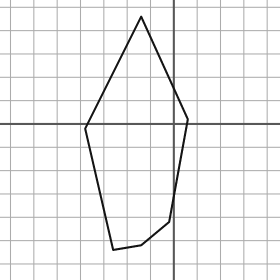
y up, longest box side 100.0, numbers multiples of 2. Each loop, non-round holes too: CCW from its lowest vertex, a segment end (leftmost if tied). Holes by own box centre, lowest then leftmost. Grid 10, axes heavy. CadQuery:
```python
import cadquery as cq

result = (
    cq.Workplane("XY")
    .moveTo(-26.0, -54.0)
    .lineTo(-14.0, -52.0)
    .lineTo(-2.0, -42.0)
    .lineTo(6.0, 2.0)
    .lineTo(-14.0, 46.0)
    .lineTo(-38.0, -2.0)
    .close()
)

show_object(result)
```